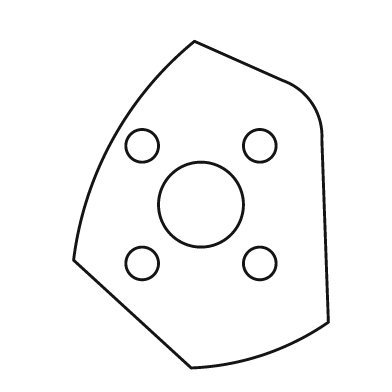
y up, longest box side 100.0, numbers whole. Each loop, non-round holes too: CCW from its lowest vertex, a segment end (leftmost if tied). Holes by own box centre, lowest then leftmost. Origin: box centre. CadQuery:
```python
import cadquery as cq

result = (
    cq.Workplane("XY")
    .moveTo(-3.0, -50.0)
    .threePointArc((19.0, -46.0), (39.0, -36.0))
    .lineTo(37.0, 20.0)
    .threePointArc((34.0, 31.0), (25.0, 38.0))
    .lineTo(-2.0, 50.0)
    .threePointArc((-27.0, 20.0), (-39.0, -17.0))
    .close()
    .moveTo(-18.0, -18.0)
    .circle(5.0)
    .moveTo(18.0, -18.0)
    .circle(5.0)
    .moveTo(0.0, 0.0)
    .circle(13.0)
    .moveTo(-18.0, 18.0)
    .circle(5.0)
    .moveTo(18.0, 18.0)
    .circle(5.0)
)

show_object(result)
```